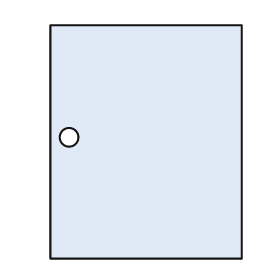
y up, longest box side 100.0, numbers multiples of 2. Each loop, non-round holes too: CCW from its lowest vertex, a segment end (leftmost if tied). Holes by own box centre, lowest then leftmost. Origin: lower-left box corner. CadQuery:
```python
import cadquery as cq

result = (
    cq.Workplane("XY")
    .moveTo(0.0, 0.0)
    .lineTo(82.0, 0.0)
    .lineTo(82.0, 100.0)
    .lineTo(0.0, 100.0)
    .close()
    .moveTo(8.0, 52.0)
    .circle(4.0)
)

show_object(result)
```